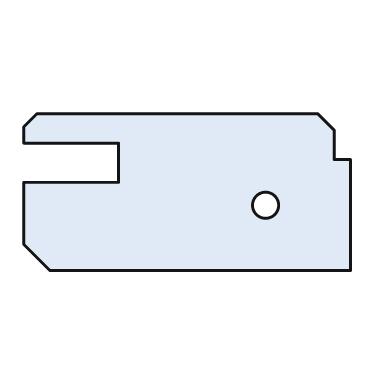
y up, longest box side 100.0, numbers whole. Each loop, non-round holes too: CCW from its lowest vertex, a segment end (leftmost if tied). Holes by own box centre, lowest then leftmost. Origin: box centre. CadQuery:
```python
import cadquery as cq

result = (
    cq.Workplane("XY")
    .moveTo(-42.0, -24.0)
    .lineTo(50.0, -24.0)
    .lineTo(50.0, 10.0)
    .lineTo(45.0, 10.0)
    .lineTo(45.0, 19.0)
    .lineTo(40.0, 24.0)
    .lineTo(-46.0, 24.0)
    .lineTo(-50.0, 20.0)
    .lineTo(-50.0, 15.0)
    .lineTo(-21.0, 15.0)
    .lineTo(-21.0, 3.0)
    .lineTo(-50.0, 3.0)
    .lineTo(-50.0, -16.0)
    .close()
    .moveTo(24.0, -4.0)
    .circle(4.0)
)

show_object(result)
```